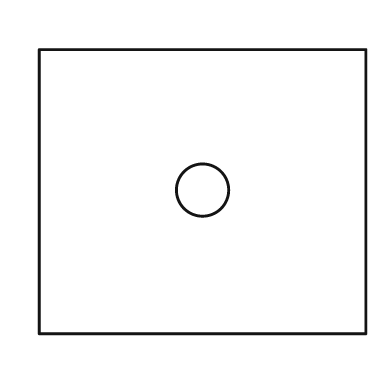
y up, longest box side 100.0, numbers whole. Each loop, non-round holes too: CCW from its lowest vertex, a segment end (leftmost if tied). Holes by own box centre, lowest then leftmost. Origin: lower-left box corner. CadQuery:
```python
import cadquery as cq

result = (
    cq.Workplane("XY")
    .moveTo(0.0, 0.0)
    .lineTo(100.0, 0.0)
    .lineTo(100.0, 87.0)
    .lineTo(0.0, 87.0)
    .close()
    .moveTo(50.0, 44.0)
    .circle(8.0)
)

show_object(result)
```